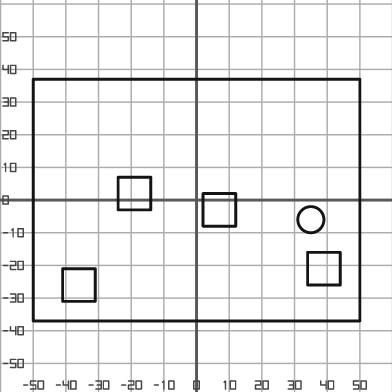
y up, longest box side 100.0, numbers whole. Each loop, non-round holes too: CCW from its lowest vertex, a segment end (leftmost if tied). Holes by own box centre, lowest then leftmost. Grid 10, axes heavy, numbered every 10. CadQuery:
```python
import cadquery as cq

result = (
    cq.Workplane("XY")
    .moveTo(-50.0, -37.0)
    .lineTo(50.0, -37.0)
    .lineTo(50.0, 37.0)
    .lineTo(-50.0, 37.0)
    .close()
    .moveTo(-41.0, -31.0)
    .lineTo(-31.0, -31.0)
    .lineTo(-31.0, -21.0)
    .lineTo(-41.0, -21.0)
    .close()
    .moveTo(34.0, -26.0)
    .lineTo(44.0, -26.0)
    .lineTo(44.0, -16.0)
    .lineTo(34.0, -16.0)
    .close()
    .moveTo(35.0, -6.0)
    .circle(4.0)
    .moveTo(2.0, -8.0)
    .lineTo(12.0, -8.0)
    .lineTo(12.0, 2.0)
    .lineTo(2.0, 2.0)
    .close()
    .moveTo(-24.0, -3.0)
    .lineTo(-14.0, -3.0)
    .lineTo(-14.0, 7.0)
    .lineTo(-24.0, 7.0)
    .close()
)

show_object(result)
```